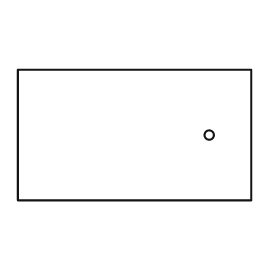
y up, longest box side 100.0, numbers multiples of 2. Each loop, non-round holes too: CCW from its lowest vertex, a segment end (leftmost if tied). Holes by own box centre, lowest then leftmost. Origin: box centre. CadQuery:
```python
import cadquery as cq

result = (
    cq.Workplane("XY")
    .moveTo(-50.0, -28.0)
    .lineTo(50.0, -28.0)
    .lineTo(50.0, 28.0)
    .lineTo(-50.0, 28.0)
    .close()
    .moveTo(32.0, 0.0)
    .circle(2.0)
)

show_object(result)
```